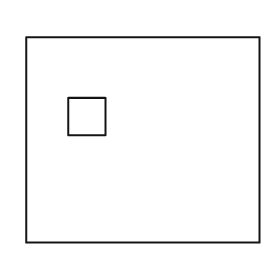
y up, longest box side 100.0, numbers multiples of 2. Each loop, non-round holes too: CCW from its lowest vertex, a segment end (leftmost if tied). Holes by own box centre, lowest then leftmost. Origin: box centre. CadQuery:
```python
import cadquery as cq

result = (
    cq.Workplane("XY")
    .moveTo(-50.0, -44.0)
    .lineTo(50.0, -44.0)
    .lineTo(50.0, 44.0)
    .lineTo(-50.0, 44.0)
    .close()
    .moveTo(-32.0, 2.0)
    .lineTo(-16.0, 2.0)
    .lineTo(-16.0, 18.0)
    .lineTo(-32.0, 18.0)
    .close()
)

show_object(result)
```